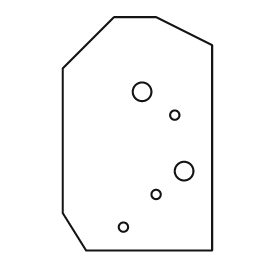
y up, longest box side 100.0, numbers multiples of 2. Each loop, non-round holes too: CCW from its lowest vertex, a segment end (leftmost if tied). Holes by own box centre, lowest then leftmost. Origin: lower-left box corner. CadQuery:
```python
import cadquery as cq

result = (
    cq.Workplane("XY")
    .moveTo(10.0, 0.0)
    .lineTo(64.0, 0.0)
    .lineTo(64.0, 88.0)
    .lineTo(40.0, 100.0)
    .lineTo(22.0, 100.0)
    .lineTo(0.0, 78.0)
    .lineTo(0.0, 16.0)
    .close()
    .moveTo(26.0, 10.0)
    .circle(2.0)
    .moveTo(40.0, 24.0)
    .circle(2.0)
    .moveTo(52.0, 34.0)
    .circle(4.0)
    .moveTo(48.0, 58.0)
    .circle(2.0)
    .moveTo(34.0, 68.0)
    .circle(4.0)
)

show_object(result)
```